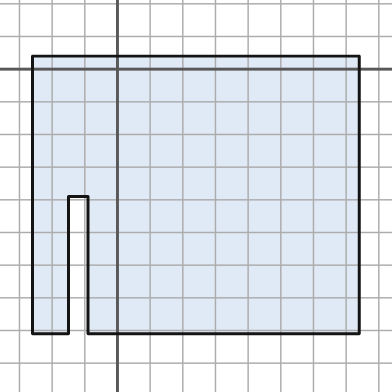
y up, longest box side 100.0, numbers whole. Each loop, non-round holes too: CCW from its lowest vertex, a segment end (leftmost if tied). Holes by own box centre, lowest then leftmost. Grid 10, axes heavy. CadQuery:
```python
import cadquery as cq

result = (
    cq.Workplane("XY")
    .moveTo(-26.0, -81.0)
    .lineTo(-15.0, -81.0)
    .lineTo(-15.0, -39.0)
    .lineTo(-9.0, -39.0)
    .lineTo(-9.0, -81.0)
    .lineTo(74.0, -81.0)
    .lineTo(74.0, 4.0)
    .lineTo(-26.0, 4.0)
    .close()
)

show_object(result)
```